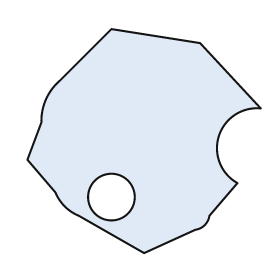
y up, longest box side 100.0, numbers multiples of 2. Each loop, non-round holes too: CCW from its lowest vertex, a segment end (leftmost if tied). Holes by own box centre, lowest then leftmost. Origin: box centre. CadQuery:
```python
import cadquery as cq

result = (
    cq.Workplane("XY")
    .moveTo(0.0, -48.0)
    .lineTo(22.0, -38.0)
    .threePointArc((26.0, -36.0), (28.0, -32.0))
    .lineTo(40.0, -18.0)
    .threePointArc((32.0, 2.0), (50.0, 14.0))
    .lineTo(24.0, 42.0)
    .lineTo(-14.0, 48.0)
    .lineTo(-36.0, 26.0)
    .threePointArc((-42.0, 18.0), (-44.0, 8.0))
    .lineTo(-50.0, -8.0)
    .lineTo(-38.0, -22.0)
    .threePointArc((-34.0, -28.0), (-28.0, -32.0))
    .close()
    .moveTo(-14.0, -24.0)
    .circle(10.0)
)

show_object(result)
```